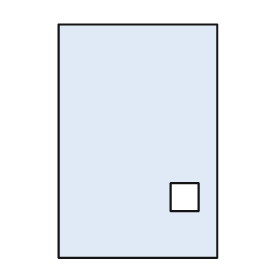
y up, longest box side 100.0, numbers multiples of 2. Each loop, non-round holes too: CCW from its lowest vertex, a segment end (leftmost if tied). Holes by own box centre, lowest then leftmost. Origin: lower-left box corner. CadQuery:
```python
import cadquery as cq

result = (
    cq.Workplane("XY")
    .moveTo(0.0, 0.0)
    .lineTo(68.0, 0.0)
    .lineTo(68.0, 100.0)
    .lineTo(0.0, 100.0)
    .close()
    .moveTo(48.0, 20.0)
    .lineTo(60.0, 20.0)
    .lineTo(60.0, 32.0)
    .lineTo(48.0, 32.0)
    .close()
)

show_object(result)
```